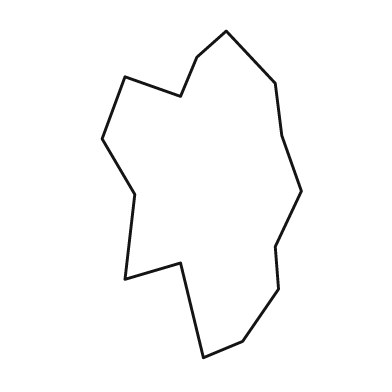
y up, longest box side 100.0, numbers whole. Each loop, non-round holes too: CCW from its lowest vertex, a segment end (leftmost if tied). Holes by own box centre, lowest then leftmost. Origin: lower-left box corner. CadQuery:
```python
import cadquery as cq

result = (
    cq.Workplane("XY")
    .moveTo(31.0, 0.0)
    .lineTo(43.0, 5.0)
    .lineTo(54.0, 21.0)
    .lineTo(53.0, 34.0)
    .lineTo(61.0, 51.0)
    .lineTo(55.0, 68.0)
    .lineTo(53.0, 84.0)
    .lineTo(38.0, 100.0)
    .lineTo(29.0, 92.0)
    .lineTo(24.0, 80.0)
    .lineTo(7.0, 86.0)
    .lineTo(0.0, 67.0)
    .lineTo(10.0, 50.0)
    .lineTo(7.0, 24.0)
    .lineTo(24.0, 29.0)
    .close()
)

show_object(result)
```